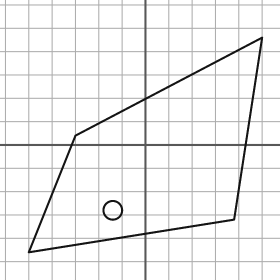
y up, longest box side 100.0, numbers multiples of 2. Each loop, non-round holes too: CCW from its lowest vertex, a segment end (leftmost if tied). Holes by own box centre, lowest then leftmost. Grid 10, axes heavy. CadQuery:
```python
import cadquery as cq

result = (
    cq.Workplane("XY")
    .moveTo(-50.0, -46.0)
    .lineTo(38.0, -32.0)
    .lineTo(50.0, 46.0)
    .lineTo(-30.0, 4.0)
    .close()
    .moveTo(-14.0, -28.0)
    .circle(4.0)
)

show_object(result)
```